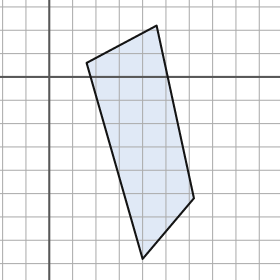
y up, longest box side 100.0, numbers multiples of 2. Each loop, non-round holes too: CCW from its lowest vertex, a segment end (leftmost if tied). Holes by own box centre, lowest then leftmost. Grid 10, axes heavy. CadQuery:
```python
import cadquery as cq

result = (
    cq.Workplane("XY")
    .moveTo(40.0, -78.0)
    .lineTo(62.0, -52.0)
    .lineTo(46.0, 22.0)
    .lineTo(16.0, 6.0)
    .close()
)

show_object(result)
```